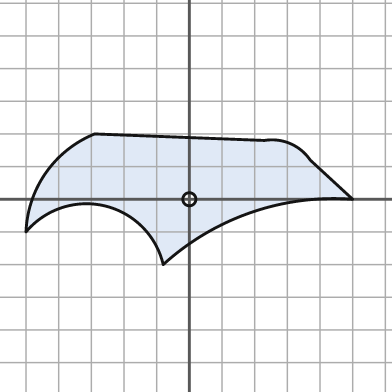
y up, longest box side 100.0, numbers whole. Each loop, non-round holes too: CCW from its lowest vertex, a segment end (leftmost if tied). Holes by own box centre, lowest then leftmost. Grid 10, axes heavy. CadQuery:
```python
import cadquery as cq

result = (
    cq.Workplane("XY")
    .moveTo(-8.0, -20.0)
    .threePointArc((19.0, -4.0), (50.0, 0.0))
    .lineTo(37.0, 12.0)
    .threePointArc((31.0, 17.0), (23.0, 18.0))
    .lineTo(-29.0, 20.0)
    .threePointArc((-44.0, 8.0), (-50.0, -10.0))
    .threePointArc((-26.0, -2.0), (-8.0, -20.0))
    .close()
    .moveTo(0.0, 0.0)
    .circle(2.0)
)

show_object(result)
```